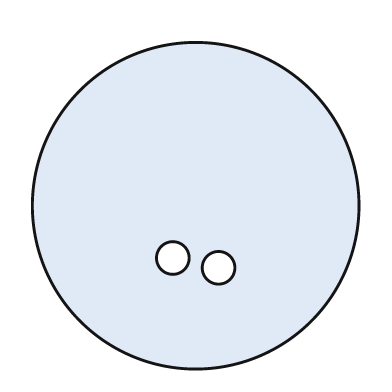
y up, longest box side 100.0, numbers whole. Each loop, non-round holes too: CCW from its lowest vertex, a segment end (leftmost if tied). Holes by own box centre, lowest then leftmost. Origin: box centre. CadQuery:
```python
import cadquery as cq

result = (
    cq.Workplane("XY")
    .moveTo(0.0, 0.0)
    .circle(50.0)
    .moveTo(7.0, -19.0)
    .circle(5.0)
    .moveTo(-7.0, -16.0)
    .circle(5.0)
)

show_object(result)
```